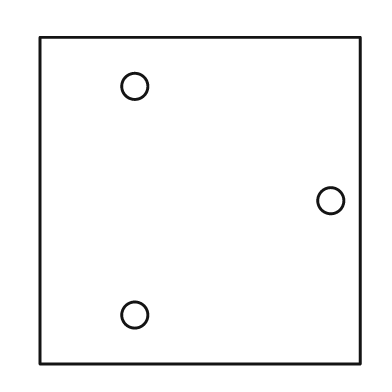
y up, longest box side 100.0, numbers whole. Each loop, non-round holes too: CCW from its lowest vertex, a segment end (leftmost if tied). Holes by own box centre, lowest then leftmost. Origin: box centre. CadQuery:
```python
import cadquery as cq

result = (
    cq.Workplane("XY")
    .moveTo(-49.0, -50.0)
    .lineTo(49.0, -50.0)
    .lineTo(49.0, 50.0)
    .lineTo(-49.0, 50.0)
    .close()
    .moveTo(-20.0, -35.0)
    .circle(4.0)
    .moveTo(40.0, 0.0)
    .circle(4.0)
    .moveTo(-20.0, 35.0)
    .circle(4.0)
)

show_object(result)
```